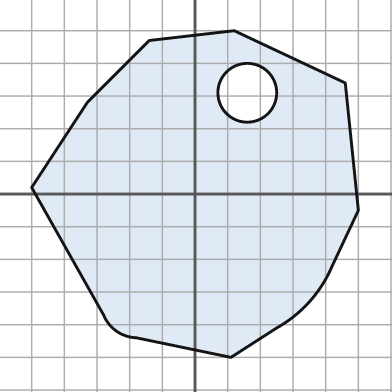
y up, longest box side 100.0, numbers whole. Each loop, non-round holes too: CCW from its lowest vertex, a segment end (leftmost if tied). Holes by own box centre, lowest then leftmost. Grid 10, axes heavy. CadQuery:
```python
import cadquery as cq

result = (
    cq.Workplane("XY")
    .moveTo(11.0, -50.0)
    .lineTo(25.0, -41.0)
    .threePointArc((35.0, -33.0), (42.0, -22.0))
    .lineTo(50.0, -5.0)
    .lineTo(46.0, 34.0)
    .lineTo(12.0, 50.0)
    .lineTo(-14.0, 47.0)
    .lineTo(-33.0, 28.0)
    .lineTo(-50.0, 2.0)
    .lineTo(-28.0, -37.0)
    .threePointArc((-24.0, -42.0), (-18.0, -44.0))
    .close()
    .moveTo(16.0, 31.0)
    .circle(9.0)
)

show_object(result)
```